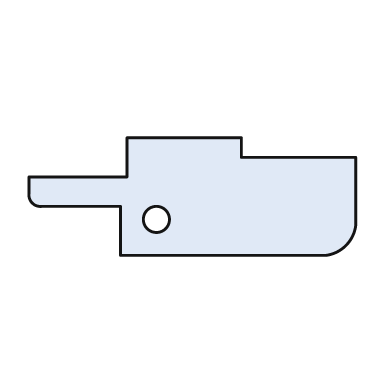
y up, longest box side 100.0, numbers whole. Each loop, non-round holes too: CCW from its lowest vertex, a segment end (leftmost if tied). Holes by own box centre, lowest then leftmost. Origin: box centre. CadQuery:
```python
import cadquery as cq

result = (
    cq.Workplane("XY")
    .moveTo(-22.0, -18.0)
    .lineTo(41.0, -18.0)
    .threePointArc((47.0, -15.0), (50.0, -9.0))
    .lineTo(50.0, 12.0)
    .lineTo(15.0, 12.0)
    .lineTo(15.0, 18.0)
    .lineTo(-20.0, 18.0)
    .lineTo(-20.0, 6.0)
    .lineTo(-50.0, 6.0)
    .lineTo(-50.0, 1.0)
    .threePointArc((-49.0, -2.0), (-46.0, -3.0))
    .lineTo(-22.0, -3.0)
    .close()
    .moveTo(-11.0, -7.0)
    .circle(4.0)
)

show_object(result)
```